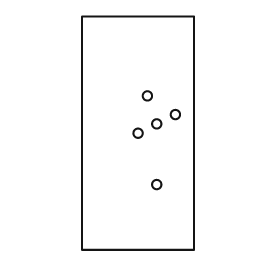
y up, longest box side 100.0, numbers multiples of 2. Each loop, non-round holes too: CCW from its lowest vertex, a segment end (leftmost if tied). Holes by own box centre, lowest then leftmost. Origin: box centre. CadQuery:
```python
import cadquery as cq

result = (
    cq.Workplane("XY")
    .moveTo(-24.0, -50.0)
    .lineTo(24.0, -50.0)
    .lineTo(24.0, 50.0)
    .lineTo(-24.0, 50.0)
    .close()
    .moveTo(8.0, -22.0)
    .circle(2.0)
    .moveTo(0.0, 0.0)
    .circle(2.0)
    .moveTo(8.0, 4.0)
    .circle(2.0)
    .moveTo(16.0, 8.0)
    .circle(2.0)
    .moveTo(4.0, 16.0)
    .circle(2.0)
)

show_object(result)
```